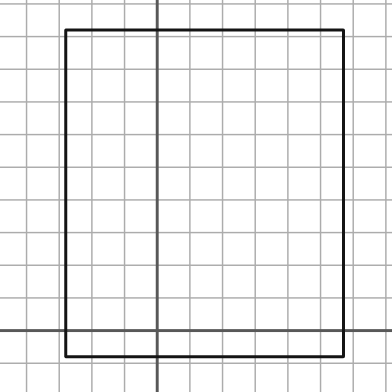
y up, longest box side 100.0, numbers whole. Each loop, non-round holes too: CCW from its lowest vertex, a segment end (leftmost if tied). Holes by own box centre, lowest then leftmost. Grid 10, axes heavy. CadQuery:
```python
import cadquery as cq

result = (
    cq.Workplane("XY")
    .moveTo(-28.0, -8.0)
    .lineTo(57.0, -8.0)
    .lineTo(57.0, 92.0)
    .lineTo(-28.0, 92.0)
    .close()
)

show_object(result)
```